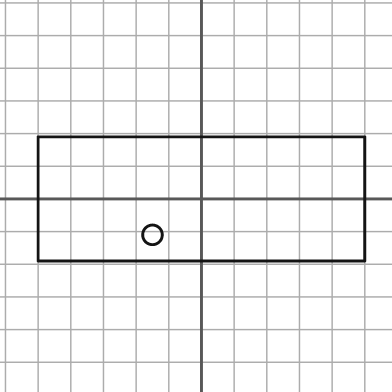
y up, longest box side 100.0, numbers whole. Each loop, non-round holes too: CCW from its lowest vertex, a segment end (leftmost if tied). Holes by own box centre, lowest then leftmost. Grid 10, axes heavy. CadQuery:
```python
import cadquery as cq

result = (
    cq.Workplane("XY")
    .moveTo(-50.0, -19.0)
    .lineTo(50.0, -19.0)
    .lineTo(50.0, 19.0)
    .lineTo(-50.0, 19.0)
    .close()
    .moveTo(-15.0, -11.0)
    .circle(3.0)
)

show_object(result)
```